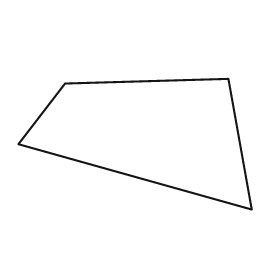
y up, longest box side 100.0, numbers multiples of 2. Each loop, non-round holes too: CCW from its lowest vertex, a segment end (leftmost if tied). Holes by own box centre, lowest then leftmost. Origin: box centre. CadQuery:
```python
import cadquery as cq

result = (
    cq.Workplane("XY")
    .moveTo(50.0, -28.0)
    .lineTo(40.0, 28.0)
    .lineTo(-30.0, 26.0)
    .lineTo(-50.0, 0.0)
    .close()
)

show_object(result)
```